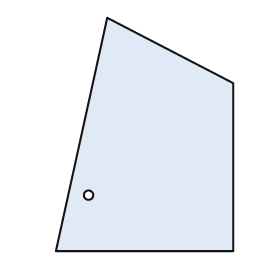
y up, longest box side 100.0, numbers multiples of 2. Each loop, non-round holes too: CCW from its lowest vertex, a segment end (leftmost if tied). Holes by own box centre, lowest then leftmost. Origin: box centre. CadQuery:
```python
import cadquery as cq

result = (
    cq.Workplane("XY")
    .moveTo(-38.0, -50.0)
    .lineTo(38.0, -50.0)
    .lineTo(38.0, 22.0)
    .lineTo(-16.0, 50.0)
    .close()
    .moveTo(-24.0, -26.0)
    .circle(2.0)
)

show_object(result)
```